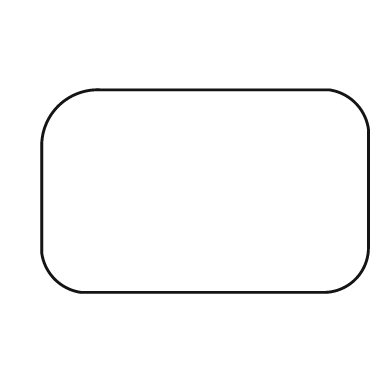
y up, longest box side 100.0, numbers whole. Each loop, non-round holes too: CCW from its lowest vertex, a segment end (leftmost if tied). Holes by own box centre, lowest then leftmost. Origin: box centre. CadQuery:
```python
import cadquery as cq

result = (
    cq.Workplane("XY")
    .moveTo(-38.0, -31.0)
    .lineTo(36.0, -31.0)
    .threePointArc((46.0, -27.0), (50.0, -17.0))
    .lineTo(50.0, 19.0)
    .threePointArc((46.0, 27.0), (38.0, 31.0))
    .lineTo(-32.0, 31.0)
    .threePointArc((-45.0, 26.0), (-50.0, 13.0))
    .lineTo(-50.0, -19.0)
    .threePointArc((-46.0, -27.0), (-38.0, -31.0))
    .close()
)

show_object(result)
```